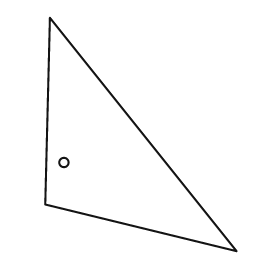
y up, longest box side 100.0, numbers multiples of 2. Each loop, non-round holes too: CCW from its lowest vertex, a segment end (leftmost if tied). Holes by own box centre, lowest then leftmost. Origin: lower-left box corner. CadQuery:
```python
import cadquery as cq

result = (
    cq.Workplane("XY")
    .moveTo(82.0, 0.0)
    .lineTo(2.0, 100.0)
    .lineTo(0.0, 20.0)
    .close()
    .moveTo(8.0, 38.0)
    .circle(2.0)
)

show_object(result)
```